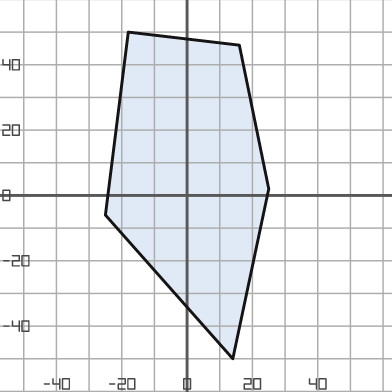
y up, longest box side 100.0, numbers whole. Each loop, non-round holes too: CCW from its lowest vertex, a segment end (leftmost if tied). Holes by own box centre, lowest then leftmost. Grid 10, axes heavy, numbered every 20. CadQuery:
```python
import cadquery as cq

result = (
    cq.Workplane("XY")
    .moveTo(14.0, -50.0)
    .lineTo(25.0, 2.0)
    .lineTo(16.0, 46.0)
    .lineTo(-18.0, 50.0)
    .lineTo(-25.0, -6.0)
    .close()
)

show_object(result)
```